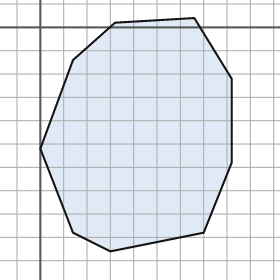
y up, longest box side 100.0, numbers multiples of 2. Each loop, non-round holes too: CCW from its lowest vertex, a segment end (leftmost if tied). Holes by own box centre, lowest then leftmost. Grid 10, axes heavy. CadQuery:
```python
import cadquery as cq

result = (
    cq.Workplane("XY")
    .moveTo(30.0, -96.0)
    .lineTo(70.0, -88.0)
    .lineTo(82.0, -58.0)
    .lineTo(82.0, -22.0)
    .lineTo(66.0, 4.0)
    .lineTo(32.0, 2.0)
    .lineTo(14.0, -14.0)
    .lineTo(0.0, -52.0)
    .lineTo(14.0, -88.0)
    .close()
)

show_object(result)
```